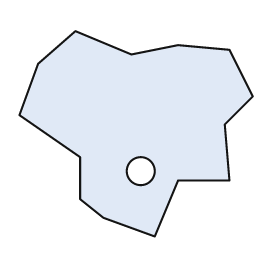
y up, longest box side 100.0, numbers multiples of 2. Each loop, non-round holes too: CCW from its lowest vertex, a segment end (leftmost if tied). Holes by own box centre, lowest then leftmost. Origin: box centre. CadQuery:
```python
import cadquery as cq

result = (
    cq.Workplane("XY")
    .moveTo(8.0, -44.0)
    .lineTo(18.0, -20.0)
    .lineTo(40.0, -20.0)
    .lineTo(38.0, 4.0)
    .lineTo(50.0, 16.0)
    .lineTo(40.0, 36.0)
    .lineTo(18.0, 38.0)
    .lineTo(-2.0, 34.0)
    .lineTo(-26.0, 44.0)
    .lineTo(-42.0, 30.0)
    .lineTo(-50.0, 8.0)
    .lineTo(-24.0, -10.0)
    .lineTo(-24.0, -28.0)
    .lineTo(-14.0, -36.0)
    .close()
    .moveTo(2.0, -16.0)
    .circle(6.0)
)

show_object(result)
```